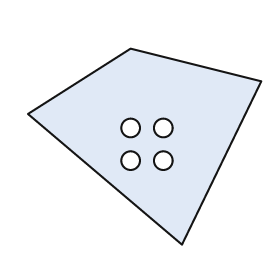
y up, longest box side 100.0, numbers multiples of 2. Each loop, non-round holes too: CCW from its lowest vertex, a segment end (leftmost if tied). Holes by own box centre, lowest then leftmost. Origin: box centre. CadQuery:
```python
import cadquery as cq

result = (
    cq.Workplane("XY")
    .moveTo(16.0, -42.0)
    .lineTo(50.0, 28.0)
    .lineTo(-6.0, 42.0)
    .lineTo(-50.0, 14.0)
    .close()
    .moveTo(-6.0, -6.0)
    .circle(4.0)
    .moveTo(8.0, -6.0)
    .circle(4.0)
    .moveTo(-6.0, 8.0)
    .circle(4.0)
    .moveTo(8.0, 8.0)
    .circle(4.0)
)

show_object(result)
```